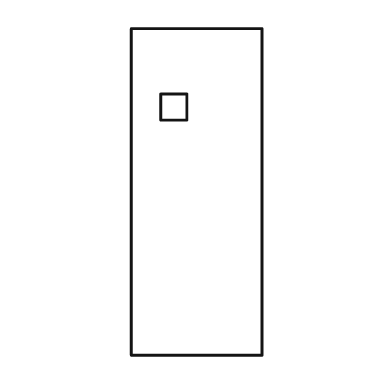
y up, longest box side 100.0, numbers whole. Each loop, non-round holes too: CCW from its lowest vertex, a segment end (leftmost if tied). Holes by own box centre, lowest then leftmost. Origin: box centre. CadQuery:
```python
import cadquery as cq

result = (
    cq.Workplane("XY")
    .moveTo(-20.0, -50.0)
    .lineTo(20.0, -50.0)
    .lineTo(20.0, 50.0)
    .lineTo(-20.0, 50.0)
    .close()
    .moveTo(-11.0, 22.0)
    .lineTo(-3.0, 22.0)
    .lineTo(-3.0, 30.0)
    .lineTo(-11.0, 30.0)
    .close()
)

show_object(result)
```